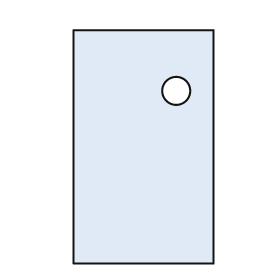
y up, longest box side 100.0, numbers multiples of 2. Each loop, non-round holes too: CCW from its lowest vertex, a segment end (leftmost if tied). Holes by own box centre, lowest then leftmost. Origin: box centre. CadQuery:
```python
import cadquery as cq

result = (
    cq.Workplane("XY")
    .moveTo(-30.0, -50.0)
    .lineTo(30.0, -50.0)
    .lineTo(30.0, 50.0)
    .lineTo(-30.0, 50.0)
    .close()
    .moveTo(14.0, 24.0)
    .circle(6.0)
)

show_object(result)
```